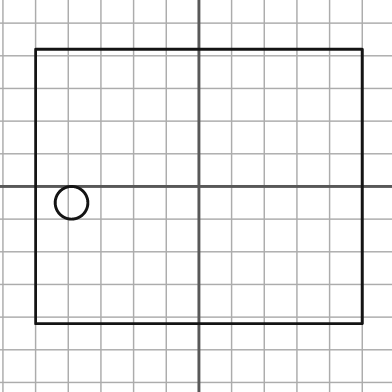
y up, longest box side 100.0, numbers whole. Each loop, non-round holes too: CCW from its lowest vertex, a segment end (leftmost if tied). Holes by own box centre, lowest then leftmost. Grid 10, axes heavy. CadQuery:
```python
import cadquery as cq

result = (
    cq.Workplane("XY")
    .moveTo(-50.0, -42.0)
    .lineTo(50.0, -42.0)
    .lineTo(50.0, 42.0)
    .lineTo(-50.0, 42.0)
    .close()
    .moveTo(-39.0, -5.0)
    .circle(5.0)
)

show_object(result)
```